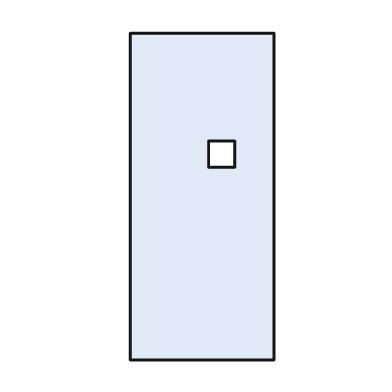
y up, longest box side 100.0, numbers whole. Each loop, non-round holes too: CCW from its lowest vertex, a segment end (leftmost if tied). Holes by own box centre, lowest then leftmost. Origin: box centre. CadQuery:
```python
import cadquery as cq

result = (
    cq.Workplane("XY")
    .moveTo(-22.0, -50.0)
    .lineTo(22.0, -50.0)
    .lineTo(22.0, 50.0)
    .lineTo(-22.0, 50.0)
    .close()
    .moveTo(2.0, 9.0)
    .lineTo(10.0, 9.0)
    .lineTo(10.0, 17.0)
    .lineTo(2.0, 17.0)
    .close()
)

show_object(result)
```